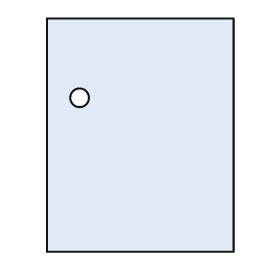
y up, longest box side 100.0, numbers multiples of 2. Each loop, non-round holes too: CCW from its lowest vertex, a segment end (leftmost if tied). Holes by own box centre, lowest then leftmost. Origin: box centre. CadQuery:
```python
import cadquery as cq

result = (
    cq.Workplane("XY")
    .moveTo(-40.0, -50.0)
    .lineTo(40.0, -50.0)
    .lineTo(40.0, 50.0)
    .lineTo(-40.0, 50.0)
    .close()
    .moveTo(-26.0, 16.0)
    .circle(4.0)
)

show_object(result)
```